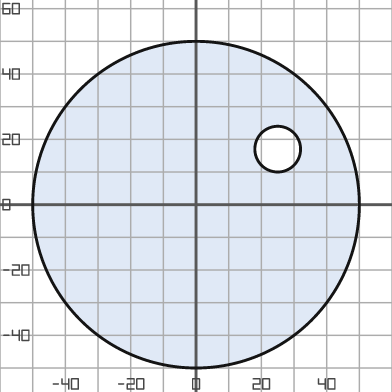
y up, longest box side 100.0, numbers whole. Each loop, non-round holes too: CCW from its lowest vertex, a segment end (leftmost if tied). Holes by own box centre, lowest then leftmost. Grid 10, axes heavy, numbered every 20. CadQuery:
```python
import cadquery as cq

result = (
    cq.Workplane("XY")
    .moveTo(0.0, 0.0)
    .circle(50.0)
    .moveTo(25.0, 17.0)
    .circle(7.0)
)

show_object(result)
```